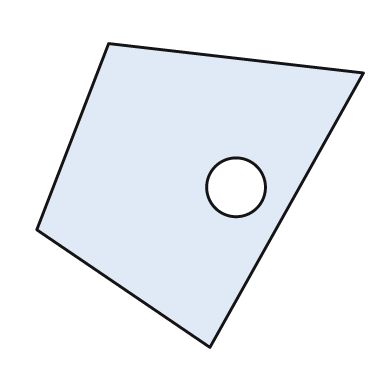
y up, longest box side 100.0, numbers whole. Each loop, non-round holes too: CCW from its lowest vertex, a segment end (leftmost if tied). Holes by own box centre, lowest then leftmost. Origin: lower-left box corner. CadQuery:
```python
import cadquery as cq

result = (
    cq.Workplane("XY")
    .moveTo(53.0, 0.0)
    .lineTo(100.0, 84.0)
    .lineTo(22.0, 93.0)
    .lineTo(0.0, 36.0)
    .close()
    .moveTo(61.0, 49.0)
    .circle(9.0)
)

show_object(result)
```